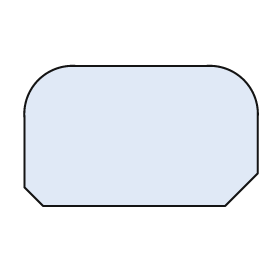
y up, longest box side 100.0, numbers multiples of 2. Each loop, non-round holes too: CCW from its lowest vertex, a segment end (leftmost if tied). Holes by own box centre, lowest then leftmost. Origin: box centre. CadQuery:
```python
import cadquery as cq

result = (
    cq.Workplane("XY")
    .moveTo(-42.0, -30.0)
    .lineTo(36.0, -30.0)
    .lineTo(50.0, -16.0)
    .lineTo(50.0, 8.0)
    .threePointArc((44.0, 24.0), (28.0, 30.0))
    .lineTo(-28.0, 30.0)
    .threePointArc((-44.0, 24.0), (-50.0, 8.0))
    .lineTo(-50.0, -22.0)
    .close()
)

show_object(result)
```